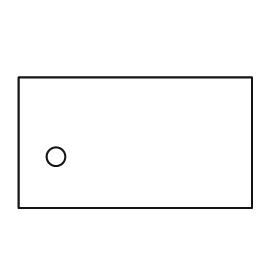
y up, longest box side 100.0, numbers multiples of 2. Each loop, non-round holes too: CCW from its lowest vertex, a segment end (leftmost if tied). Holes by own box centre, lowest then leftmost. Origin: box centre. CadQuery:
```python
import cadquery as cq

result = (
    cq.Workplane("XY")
    .moveTo(-50.0, -28.0)
    .lineTo(50.0, -28.0)
    .lineTo(50.0, 28.0)
    .lineTo(-50.0, 28.0)
    .close()
    .moveTo(-34.0, -6.0)
    .circle(4.0)
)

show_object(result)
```